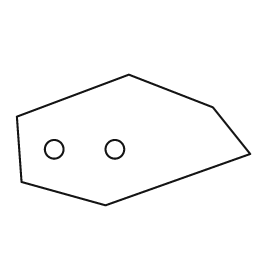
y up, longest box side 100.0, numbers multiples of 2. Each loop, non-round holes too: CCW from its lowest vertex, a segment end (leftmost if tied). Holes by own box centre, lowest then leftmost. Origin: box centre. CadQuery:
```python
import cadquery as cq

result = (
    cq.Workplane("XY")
    .moveTo(-12.0, -28.0)
    .lineTo(50.0, -6.0)
    .lineTo(34.0, 14.0)
    .lineTo(-2.0, 28.0)
    .lineTo(-50.0, 10.0)
    .lineTo(-48.0, -18.0)
    .close()
    .moveTo(-34.0, -4.0)
    .circle(4.0)
    .moveTo(-8.0, -4.0)
    .circle(4.0)
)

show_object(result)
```